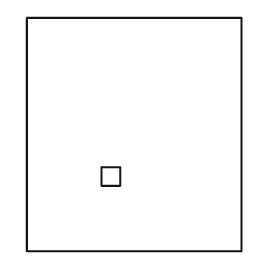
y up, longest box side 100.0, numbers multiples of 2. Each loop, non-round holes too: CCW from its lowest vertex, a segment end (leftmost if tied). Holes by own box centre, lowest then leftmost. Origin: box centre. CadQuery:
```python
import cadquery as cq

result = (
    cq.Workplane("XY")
    .moveTo(-46.0, -50.0)
    .lineTo(46.0, -50.0)
    .lineTo(46.0, 50.0)
    .lineTo(-46.0, 50.0)
    .close()
    .moveTo(-14.0, -22.0)
    .lineTo(-6.0, -22.0)
    .lineTo(-6.0, -14.0)
    .lineTo(-14.0, -14.0)
    .close()
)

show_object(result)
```